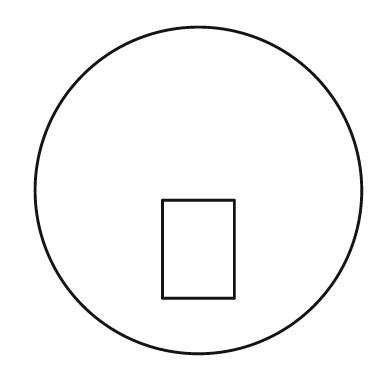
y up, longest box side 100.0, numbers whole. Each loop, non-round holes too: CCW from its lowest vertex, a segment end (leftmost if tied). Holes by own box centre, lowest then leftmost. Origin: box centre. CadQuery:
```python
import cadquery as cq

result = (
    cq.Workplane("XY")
    .moveTo(0.0, 0.0)
    .circle(50.0)
    .moveTo(-11.0, -33.0)
    .lineTo(11.0, -33.0)
    .lineTo(11.0, -3.0)
    .lineTo(-11.0, -3.0)
    .close()
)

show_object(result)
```